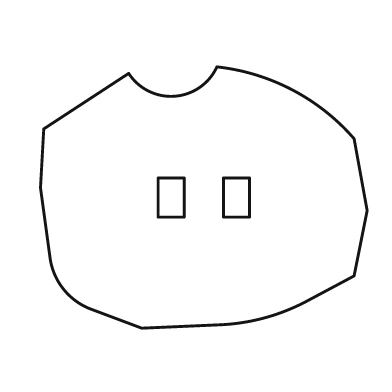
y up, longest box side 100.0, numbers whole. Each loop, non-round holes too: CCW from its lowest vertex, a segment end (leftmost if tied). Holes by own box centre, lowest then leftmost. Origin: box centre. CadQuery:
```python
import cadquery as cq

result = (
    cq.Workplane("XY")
    .moveTo(-19.0, -40.0)
    .lineTo(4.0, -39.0)
    .threePointArc((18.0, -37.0), (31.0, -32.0))
    .lineTo(46.0, -24.0)
    .lineTo(50.0, -4.0)
    .lineTo(46.0, 18.0)
    .threePointArc((27.0, 33.0), (4.0, 40.0))
    .threePointArc((-9.0, 31.0), (-23.0, 38.0))
    .lineTo(-49.0, 21.0)
    .lineTo(-50.0, 3.0)
    .lineTo(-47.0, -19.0)
    .threePointArc((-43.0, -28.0), (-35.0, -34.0))
    .close()
    .moveTo(-14.0, -6.0)
    .lineTo(-6.0, -6.0)
    .lineTo(-6.0, 6.0)
    .lineTo(-14.0, 6.0)
    .close()
    .moveTo(6.0, -6.0)
    .lineTo(14.0, -6.0)
    .lineTo(14.0, 6.0)
    .lineTo(6.0, 6.0)
    .close()
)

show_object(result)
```